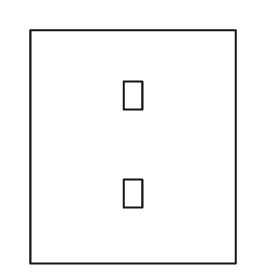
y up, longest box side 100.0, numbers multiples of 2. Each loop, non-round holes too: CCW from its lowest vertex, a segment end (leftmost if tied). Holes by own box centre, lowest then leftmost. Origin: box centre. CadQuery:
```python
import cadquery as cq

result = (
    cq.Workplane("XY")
    .moveTo(-44.0, -50.0)
    .lineTo(44.0, -50.0)
    .lineTo(44.0, 50.0)
    .lineTo(-44.0, 50.0)
    .close()
    .moveTo(-4.0, -26.0)
    .lineTo(4.0, -26.0)
    .lineTo(4.0, -14.0)
    .lineTo(-4.0, -14.0)
    .close()
    .moveTo(-4.0, 16.0)
    .lineTo(4.0, 16.0)
    .lineTo(4.0, 28.0)
    .lineTo(-4.0, 28.0)
    .close()
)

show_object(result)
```